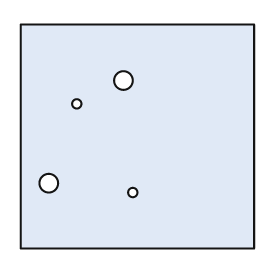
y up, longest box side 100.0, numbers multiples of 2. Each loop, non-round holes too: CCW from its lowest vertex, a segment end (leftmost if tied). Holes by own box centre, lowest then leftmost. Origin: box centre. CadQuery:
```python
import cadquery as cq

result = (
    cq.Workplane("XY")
    .moveTo(-50.0, -48.0)
    .lineTo(50.0, -48.0)
    .lineTo(50.0, 48.0)
    .lineTo(-50.0, 48.0)
    .close()
    .moveTo(-2.0, -24.0)
    .circle(2.0)
    .moveTo(-38.0, -20.0)
    .circle(4.0)
    .moveTo(-26.0, 14.0)
    .circle(2.0)
    .moveTo(-6.0, 24.0)
    .circle(4.0)
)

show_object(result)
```